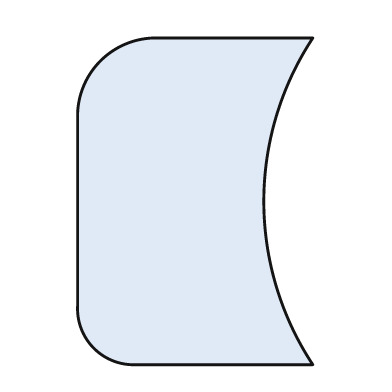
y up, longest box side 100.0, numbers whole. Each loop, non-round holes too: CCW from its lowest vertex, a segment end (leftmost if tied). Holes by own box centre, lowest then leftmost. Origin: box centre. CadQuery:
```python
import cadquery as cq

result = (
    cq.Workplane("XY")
    .moveTo(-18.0, -50.0)
    .lineTo(36.0, -50.0)
    .threePointArc((21.0, 0.0), (36.0, 50.0))
    .lineTo(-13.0, 50.0)
    .threePointArc((-29.0, 43.0), (-36.0, 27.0))
    .lineTo(-36.0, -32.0)
    .threePointArc((-31.0, -45.0), (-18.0, -50.0))
    .close()
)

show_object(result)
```